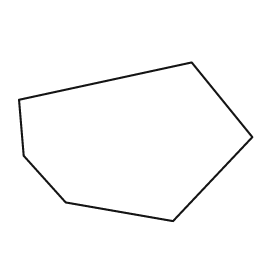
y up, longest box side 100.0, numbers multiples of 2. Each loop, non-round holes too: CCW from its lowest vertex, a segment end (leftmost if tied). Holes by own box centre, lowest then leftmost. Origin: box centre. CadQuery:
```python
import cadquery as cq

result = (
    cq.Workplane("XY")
    .moveTo(16.0, -34.0)
    .lineTo(50.0, 2.0)
    .lineTo(24.0, 34.0)
    .lineTo(-50.0, 18.0)
    .lineTo(-48.0, -6.0)
    .lineTo(-30.0, -26.0)
    .close()
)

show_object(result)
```